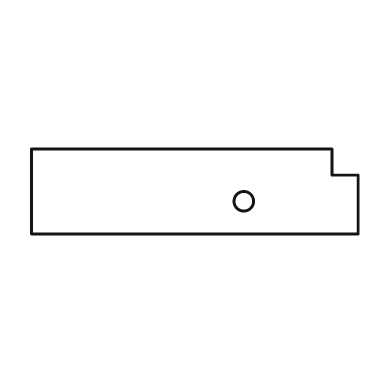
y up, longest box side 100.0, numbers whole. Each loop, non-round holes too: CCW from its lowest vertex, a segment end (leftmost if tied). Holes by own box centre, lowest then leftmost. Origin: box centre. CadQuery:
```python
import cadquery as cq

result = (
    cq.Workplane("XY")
    .moveTo(-50.0, -13.0)
    .lineTo(50.0, -13.0)
    .lineTo(50.0, 5.0)
    .lineTo(42.0, 5.0)
    .lineTo(42.0, 13.0)
    .lineTo(-50.0, 13.0)
    .close()
    .moveTo(15.0, -3.0)
    .circle(3.0)
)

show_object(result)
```